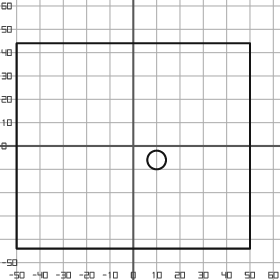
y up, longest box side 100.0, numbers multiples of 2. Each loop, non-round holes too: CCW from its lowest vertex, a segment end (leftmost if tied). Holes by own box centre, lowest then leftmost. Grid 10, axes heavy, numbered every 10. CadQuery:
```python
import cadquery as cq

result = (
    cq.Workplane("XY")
    .moveTo(-50.0, -44.0)
    .lineTo(50.0, -44.0)
    .lineTo(50.0, 44.0)
    .lineTo(-50.0, 44.0)
    .close()
    .moveTo(10.0, -6.0)
    .circle(4.0)
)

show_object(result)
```